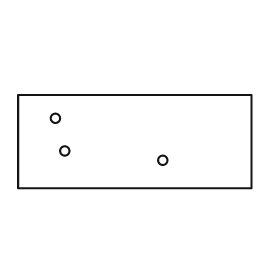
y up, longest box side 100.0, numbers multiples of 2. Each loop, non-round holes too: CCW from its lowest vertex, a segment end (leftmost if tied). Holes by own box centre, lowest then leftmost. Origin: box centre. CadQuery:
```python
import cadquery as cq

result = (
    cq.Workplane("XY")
    .moveTo(-50.0, -20.0)
    .lineTo(50.0, -20.0)
    .lineTo(50.0, 20.0)
    .lineTo(-50.0, 20.0)
    .close()
    .moveTo(12.0, -8.0)
    .circle(2.0)
    .moveTo(-30.0, -4.0)
    .circle(2.0)
    .moveTo(-34.0, 10.0)
    .circle(2.0)
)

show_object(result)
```